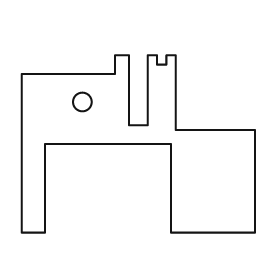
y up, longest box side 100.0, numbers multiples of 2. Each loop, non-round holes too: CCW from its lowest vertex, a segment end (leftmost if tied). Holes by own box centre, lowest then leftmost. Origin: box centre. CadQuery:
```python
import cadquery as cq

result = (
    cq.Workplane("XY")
    .moveTo(-50.0, -38.0)
    .lineTo(-40.0, -38.0)
    .lineTo(-40.0, 0.0)
    .lineTo(14.0, 0.0)
    .lineTo(14.0, -38.0)
    .lineTo(50.0, -38.0)
    .lineTo(50.0, 6.0)
    .lineTo(16.0, 6.0)
    .lineTo(16.0, 38.0)
    .lineTo(12.0, 38.0)
    .lineTo(12.0, 34.0)
    .lineTo(8.0, 34.0)
    .lineTo(8.0, 38.0)
    .lineTo(4.0, 38.0)
    .lineTo(4.0, 8.0)
    .lineTo(-4.0, 8.0)
    .lineTo(-4.0, 38.0)
    .lineTo(-10.0, 38.0)
    .lineTo(-10.0, 30.0)
    .lineTo(-50.0, 30.0)
    .close()
    .moveTo(-24.0, 18.0)
    .circle(4.0)
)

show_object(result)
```